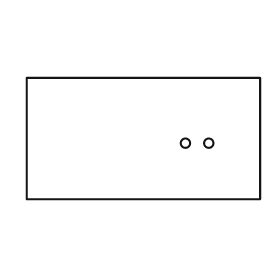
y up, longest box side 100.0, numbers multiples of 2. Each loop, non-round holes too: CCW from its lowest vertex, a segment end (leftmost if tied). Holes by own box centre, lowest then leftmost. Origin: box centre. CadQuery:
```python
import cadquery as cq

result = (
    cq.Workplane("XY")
    .moveTo(-50.0, -26.0)
    .lineTo(50.0, -26.0)
    .lineTo(50.0, 26.0)
    .lineTo(-50.0, 26.0)
    .close()
    .moveTo(18.0, -2.0)
    .circle(2.0)
    .moveTo(28.0, -2.0)
    .circle(2.0)
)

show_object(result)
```